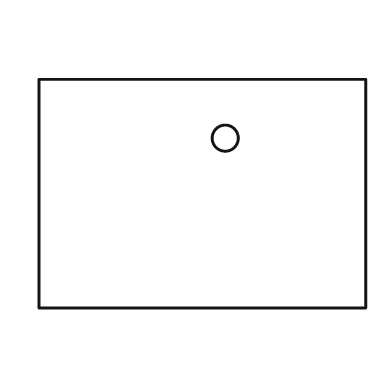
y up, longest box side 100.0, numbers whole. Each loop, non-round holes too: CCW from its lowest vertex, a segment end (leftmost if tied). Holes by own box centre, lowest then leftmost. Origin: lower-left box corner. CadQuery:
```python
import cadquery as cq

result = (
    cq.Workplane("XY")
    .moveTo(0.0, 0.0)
    .lineTo(100.0, 0.0)
    .lineTo(100.0, 70.0)
    .lineTo(0.0, 70.0)
    .close()
    .moveTo(57.0, 52.0)
    .circle(4.0)
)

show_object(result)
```